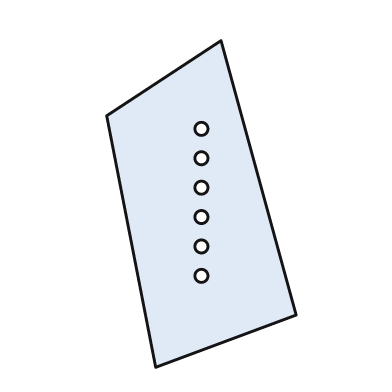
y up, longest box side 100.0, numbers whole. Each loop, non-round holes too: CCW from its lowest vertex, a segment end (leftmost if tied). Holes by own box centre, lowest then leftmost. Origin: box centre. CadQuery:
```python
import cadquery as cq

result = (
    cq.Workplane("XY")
    .moveTo(-14.0, -50.0)
    .lineTo(29.0, -34.0)
    .lineTo(6.0, 50.0)
    .lineTo(-29.0, 27.0)
    .close()
    .moveTo(0.0, -22.0)
    .circle(2.0)
    .moveTo(0.0, -13.0)
    .circle(2.0)
    .moveTo(0.0, -4.0)
    .circle(2.0)
    .moveTo(0.0, 5.0)
    .circle(2.0)
    .moveTo(0.0, 14.0)
    .circle(2.0)
    .moveTo(0.0, 23.0)
    .circle(2.0)
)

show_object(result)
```